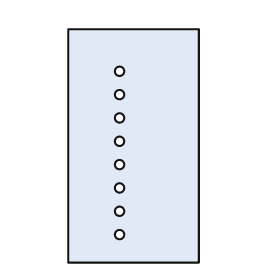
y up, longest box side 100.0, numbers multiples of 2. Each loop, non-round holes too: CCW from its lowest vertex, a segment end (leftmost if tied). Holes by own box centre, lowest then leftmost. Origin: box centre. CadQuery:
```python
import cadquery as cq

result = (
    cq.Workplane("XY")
    .moveTo(-28.0, -50.0)
    .lineTo(28.0, -50.0)
    .lineTo(28.0, 50.0)
    .lineTo(-28.0, 50.0)
    .close()
    .moveTo(-6.0, -38.0)
    .circle(2.0)
    .moveTo(-6.0, -28.0)
    .circle(2.0)
    .moveTo(-6.0, -18.0)
    .circle(2.0)
    .moveTo(-6.0, -8.0)
    .circle(2.0)
    .moveTo(-6.0, 2.0)
    .circle(2.0)
    .moveTo(-6.0, 12.0)
    .circle(2.0)
    .moveTo(-6.0, 22.0)
    .circle(2.0)
    .moveTo(-6.0, 32.0)
    .circle(2.0)
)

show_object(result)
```